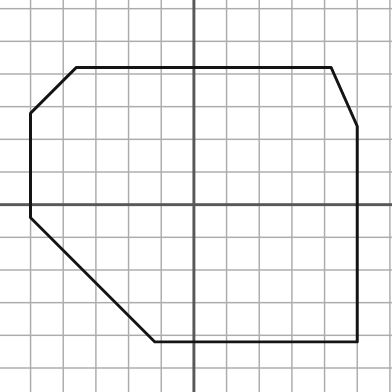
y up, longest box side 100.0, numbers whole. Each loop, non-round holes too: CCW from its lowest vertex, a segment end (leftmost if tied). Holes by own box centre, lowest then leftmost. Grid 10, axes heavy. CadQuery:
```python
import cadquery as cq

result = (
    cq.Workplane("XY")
    .moveTo(-12.0, -42.0)
    .lineTo(50.0, -42.0)
    .lineTo(50.0, 24.0)
    .lineTo(42.0, 42.0)
    .lineTo(-36.0, 42.0)
    .lineTo(-50.0, 28.0)
    .lineTo(-50.0, -4.0)
    .close()
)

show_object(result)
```